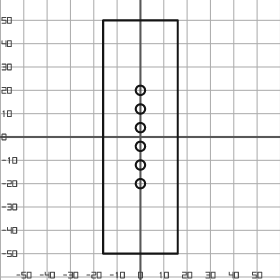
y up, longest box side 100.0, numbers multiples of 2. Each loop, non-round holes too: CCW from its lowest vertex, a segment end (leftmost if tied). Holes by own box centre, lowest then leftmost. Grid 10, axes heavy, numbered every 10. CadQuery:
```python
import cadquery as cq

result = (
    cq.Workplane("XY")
    .moveTo(-16.0, -50.0)
    .lineTo(16.0, -50.0)
    .lineTo(16.0, 50.0)
    .lineTo(-16.0, 50.0)
    .close()
    .moveTo(0.0, -20.0)
    .circle(2.0)
    .moveTo(0.0, -12.0)
    .circle(2.0)
    .moveTo(0.0, -4.0)
    .circle(2.0)
    .moveTo(0.0, 4.0)
    .circle(2.0)
    .moveTo(0.0, 12.0)
    .circle(2.0)
    .moveTo(0.0, 20.0)
    .circle(2.0)
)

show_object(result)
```